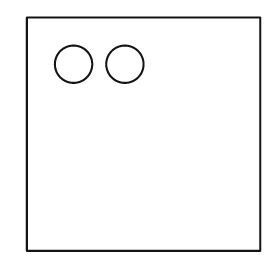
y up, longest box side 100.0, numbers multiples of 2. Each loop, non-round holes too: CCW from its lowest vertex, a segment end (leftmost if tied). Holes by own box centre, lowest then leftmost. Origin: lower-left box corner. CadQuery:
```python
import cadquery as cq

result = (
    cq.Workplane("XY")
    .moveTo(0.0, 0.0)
    .lineTo(100.0, 0.0)
    .lineTo(100.0, 100.0)
    .lineTo(0.0, 100.0)
    .close()
    .moveTo(20.0, 80.0)
    .circle(8.0)
    .moveTo(42.0, 80.0)
    .circle(8.0)
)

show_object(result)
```